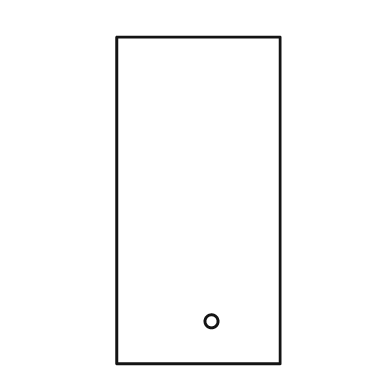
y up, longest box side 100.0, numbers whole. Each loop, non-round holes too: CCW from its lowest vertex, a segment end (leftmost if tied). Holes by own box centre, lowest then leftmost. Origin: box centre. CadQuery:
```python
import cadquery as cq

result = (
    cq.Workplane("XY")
    .moveTo(-25.0, -50.0)
    .lineTo(25.0, -50.0)
    .lineTo(25.0, 50.0)
    .lineTo(-25.0, 50.0)
    .close()
    .moveTo(4.0, -37.0)
    .circle(2.0)
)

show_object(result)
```